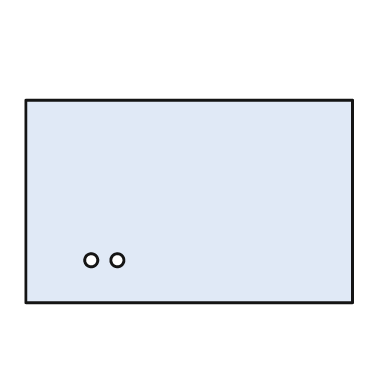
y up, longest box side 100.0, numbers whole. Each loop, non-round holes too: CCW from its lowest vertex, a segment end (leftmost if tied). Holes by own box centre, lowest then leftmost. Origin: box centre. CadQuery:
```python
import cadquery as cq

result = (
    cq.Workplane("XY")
    .moveTo(-50.0, -31.0)
    .lineTo(50.0, -31.0)
    .lineTo(50.0, 31.0)
    .lineTo(-50.0, 31.0)
    .close()
    .moveTo(-30.0, -18.0)
    .circle(2.0)
    .moveTo(-22.0, -18.0)
    .circle(2.0)
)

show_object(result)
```